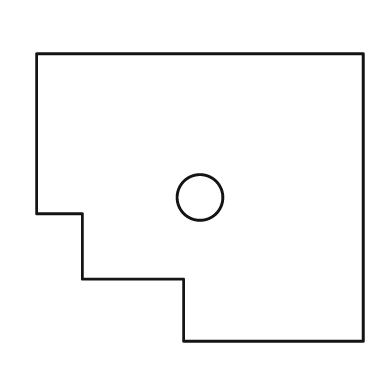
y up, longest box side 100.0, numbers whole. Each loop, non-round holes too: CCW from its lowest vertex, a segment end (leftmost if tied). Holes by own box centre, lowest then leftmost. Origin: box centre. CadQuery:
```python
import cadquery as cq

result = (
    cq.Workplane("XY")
    .moveTo(-5.0, -44.0)
    .lineTo(50.0, -44.0)
    .lineTo(50.0, 44.0)
    .lineTo(-50.0, 44.0)
    .lineTo(-50.0, -5.0)
    .lineTo(-36.0, -5.0)
    .lineTo(-36.0, -25.0)
    .lineTo(-5.0, -25.0)
    .close()
    .moveTo(0.0, 0.0)
    .circle(7.0)
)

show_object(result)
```